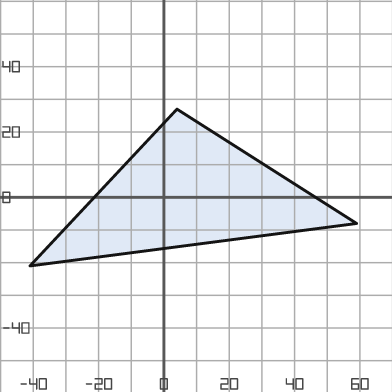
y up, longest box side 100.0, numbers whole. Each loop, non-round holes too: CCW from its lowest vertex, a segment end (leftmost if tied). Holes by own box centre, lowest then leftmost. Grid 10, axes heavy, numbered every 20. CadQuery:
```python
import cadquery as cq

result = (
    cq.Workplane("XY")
    .moveTo(-41.0, -21.0)
    .lineTo(59.0, -8.0)
    .lineTo(4.0, 27.0)
    .close()
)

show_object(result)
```